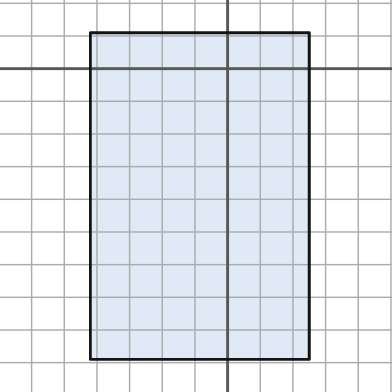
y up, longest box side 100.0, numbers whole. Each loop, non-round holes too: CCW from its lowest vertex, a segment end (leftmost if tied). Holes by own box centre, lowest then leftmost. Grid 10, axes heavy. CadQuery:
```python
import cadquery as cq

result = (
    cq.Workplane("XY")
    .moveTo(-42.0, -89.0)
    .lineTo(25.0, -89.0)
    .lineTo(25.0, 11.0)
    .lineTo(-42.0, 11.0)
    .close()
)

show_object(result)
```